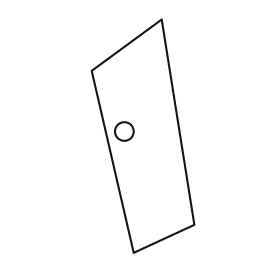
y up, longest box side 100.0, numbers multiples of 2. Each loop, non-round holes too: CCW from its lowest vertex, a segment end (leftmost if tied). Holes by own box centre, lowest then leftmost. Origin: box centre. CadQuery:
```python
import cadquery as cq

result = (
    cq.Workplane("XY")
    .moveTo(-4.0, -50.0)
    .lineTo(22.0, -38.0)
    .lineTo(8.0, 50.0)
    .lineTo(-22.0, 28.0)
    .close()
    .moveTo(-8.0, 2.0)
    .circle(4.0)
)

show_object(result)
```